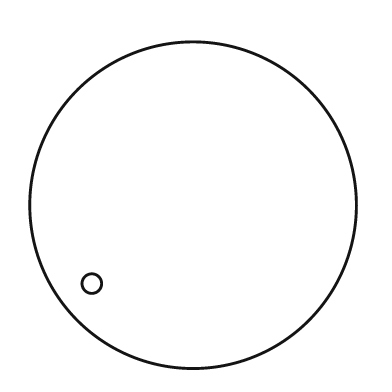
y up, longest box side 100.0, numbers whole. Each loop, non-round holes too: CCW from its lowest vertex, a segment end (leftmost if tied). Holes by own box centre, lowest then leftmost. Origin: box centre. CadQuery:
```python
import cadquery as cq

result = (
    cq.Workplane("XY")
    .moveTo(0.0, 0.0)
    .circle(50.0)
    .moveTo(-31.0, -24.0)
    .circle(3.0)
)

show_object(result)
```